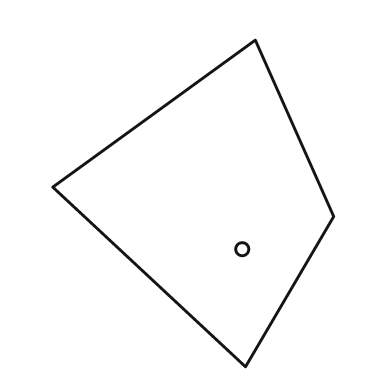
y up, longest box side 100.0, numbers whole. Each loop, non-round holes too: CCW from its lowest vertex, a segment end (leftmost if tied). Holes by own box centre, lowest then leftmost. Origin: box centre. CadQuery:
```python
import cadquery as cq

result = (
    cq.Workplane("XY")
    .moveTo(16.0, -50.0)
    .lineTo(43.0, -4.0)
    .lineTo(19.0, 50.0)
    .lineTo(-43.0, 5.0)
    .close()
    .moveTo(15.0, -14.0)
    .circle(2.0)
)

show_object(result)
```